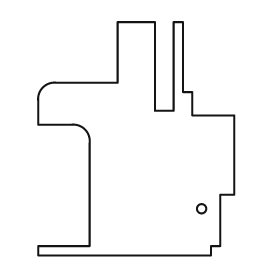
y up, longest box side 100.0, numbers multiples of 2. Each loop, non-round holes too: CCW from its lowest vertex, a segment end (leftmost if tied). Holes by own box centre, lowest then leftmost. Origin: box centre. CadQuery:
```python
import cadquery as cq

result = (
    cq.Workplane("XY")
    .moveTo(-42.0, -50.0)
    .lineTo(32.0, -50.0)
    .lineTo(32.0, -46.0)
    .lineTo(36.0, -46.0)
    .lineTo(36.0, -24.0)
    .lineTo(42.0, -24.0)
    .lineTo(42.0, 10.0)
    .lineTo(24.0, 10.0)
    .lineTo(24.0, 20.0)
    .lineTo(20.0, 20.0)
    .lineTo(20.0, 50.0)
    .lineTo(16.0, 50.0)
    .lineTo(16.0, 12.0)
    .lineTo(8.0, 12.0)
    .lineTo(8.0, 50.0)
    .lineTo(-8.0, 50.0)
    .lineTo(-8.0, 24.0)
    .lineTo(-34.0, 24.0)
    .threePointArc((-40.0, 22.0), (-42.0, 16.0))
    .lineTo(-42.0, 6.0)
    .lineTo(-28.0, 6.0)
    .threePointArc((-22.0, 4.0), (-20.0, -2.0))
    .lineTo(-20.0, -46.0)
    .lineTo(-42.0, -46.0)
    .close()
    .moveTo(28.0, -30.0)
    .circle(2.0)
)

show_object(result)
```